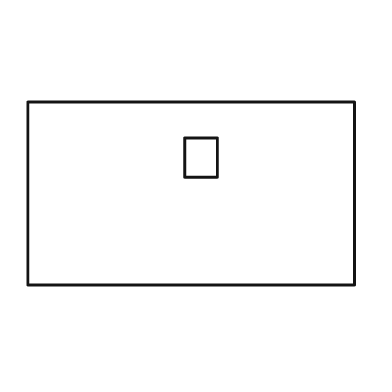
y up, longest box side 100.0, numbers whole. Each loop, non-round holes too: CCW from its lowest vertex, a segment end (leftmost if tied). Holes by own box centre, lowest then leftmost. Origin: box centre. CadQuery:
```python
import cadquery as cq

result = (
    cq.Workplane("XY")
    .moveTo(-50.0, -28.0)
    .lineTo(50.0, -28.0)
    .lineTo(50.0, 28.0)
    .lineTo(-50.0, 28.0)
    .close()
    .moveTo(-2.0, 5.0)
    .lineTo(8.0, 5.0)
    .lineTo(8.0, 17.0)
    .lineTo(-2.0, 17.0)
    .close()
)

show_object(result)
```